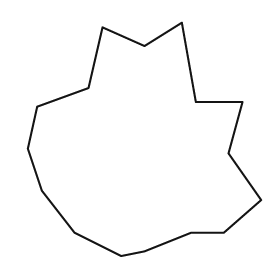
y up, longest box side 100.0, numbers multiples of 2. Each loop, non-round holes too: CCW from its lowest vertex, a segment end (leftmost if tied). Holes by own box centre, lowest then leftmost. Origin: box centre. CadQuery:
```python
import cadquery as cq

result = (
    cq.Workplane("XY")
    .moveTo(-10.0, -50.0)
    .lineTo(0.0, -48.0)
    .lineTo(20.0, -40.0)
    .lineTo(34.0, -40.0)
    .lineTo(50.0, -26.0)
    .lineTo(36.0, -6.0)
    .lineTo(42.0, 16.0)
    .lineTo(22.0, 16.0)
    .lineTo(16.0, 50.0)
    .lineTo(0.0, 40.0)
    .lineTo(-18.0, 48.0)
    .lineTo(-24.0, 22.0)
    .lineTo(-46.0, 14.0)
    .lineTo(-50.0, -4.0)
    .lineTo(-44.0, -22.0)
    .lineTo(-30.0, -40.0)
    .close()
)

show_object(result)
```